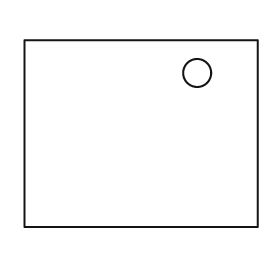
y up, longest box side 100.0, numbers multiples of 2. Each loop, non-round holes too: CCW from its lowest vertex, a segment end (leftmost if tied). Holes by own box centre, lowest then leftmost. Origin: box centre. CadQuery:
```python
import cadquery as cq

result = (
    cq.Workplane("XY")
    .moveTo(-50.0, -40.0)
    .lineTo(50.0, -40.0)
    .lineTo(50.0, 40.0)
    .lineTo(-50.0, 40.0)
    .close()
    .moveTo(24.0, 26.0)
    .circle(6.0)
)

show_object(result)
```